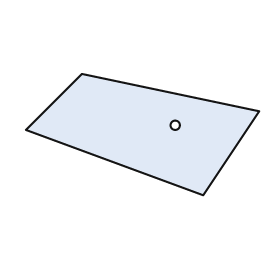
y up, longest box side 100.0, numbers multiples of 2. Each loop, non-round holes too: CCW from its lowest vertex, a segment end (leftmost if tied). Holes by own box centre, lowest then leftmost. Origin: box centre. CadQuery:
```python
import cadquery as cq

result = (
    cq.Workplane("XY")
    .moveTo(26.0, -26.0)
    .lineTo(50.0, 10.0)
    .lineTo(-26.0, 26.0)
    .lineTo(-50.0, 2.0)
    .close()
    .moveTo(14.0, 4.0)
    .circle(2.0)
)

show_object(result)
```